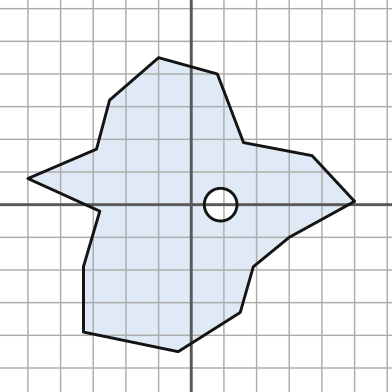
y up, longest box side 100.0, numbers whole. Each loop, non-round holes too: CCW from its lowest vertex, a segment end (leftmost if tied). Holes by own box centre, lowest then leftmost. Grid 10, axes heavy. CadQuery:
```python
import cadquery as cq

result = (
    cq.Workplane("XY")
    .moveTo(-4.0, -45.0)
    .lineTo(15.0, -33.0)
    .lineTo(19.0, -19.0)
    .lineTo(30.0, -10.0)
    .lineTo(50.0, 1.0)
    .lineTo(37.0, 15.0)
    .lineTo(16.0, 19.0)
    .lineTo(8.0, 40.0)
    .lineTo(-10.0, 45.0)
    .lineTo(-25.0, 32.0)
    .lineTo(-29.0, 17.0)
    .lineTo(-50.0, 8.0)
    .lineTo(-28.0, -2.0)
    .lineTo(-33.0, -19.0)
    .lineTo(-33.0, -39.0)
    .close()
    .moveTo(9.0, 0.0)
    .circle(5.0)
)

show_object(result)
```